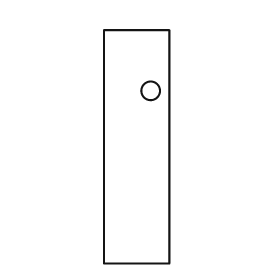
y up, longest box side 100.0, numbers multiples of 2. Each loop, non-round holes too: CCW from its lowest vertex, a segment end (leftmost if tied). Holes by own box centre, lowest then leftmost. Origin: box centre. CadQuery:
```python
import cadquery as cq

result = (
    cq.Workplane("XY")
    .moveTo(-14.0, -50.0)
    .lineTo(14.0, -50.0)
    .lineTo(14.0, 50.0)
    .lineTo(-14.0, 50.0)
    .close()
    .moveTo(6.0, 24.0)
    .circle(4.0)
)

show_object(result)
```